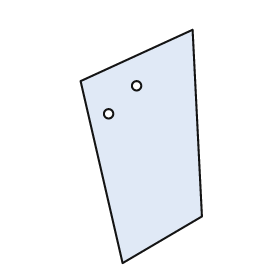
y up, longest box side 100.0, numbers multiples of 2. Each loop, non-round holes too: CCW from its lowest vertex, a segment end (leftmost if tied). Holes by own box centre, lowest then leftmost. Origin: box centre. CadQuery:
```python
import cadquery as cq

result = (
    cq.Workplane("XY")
    .moveTo(-8.0, -50.0)
    .lineTo(26.0, -30.0)
    .lineTo(22.0, 50.0)
    .lineTo(-26.0, 28.0)
    .close()
    .moveTo(-14.0, 14.0)
    .circle(2.0)
    .moveTo(-2.0, 26.0)
    .circle(2.0)
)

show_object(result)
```